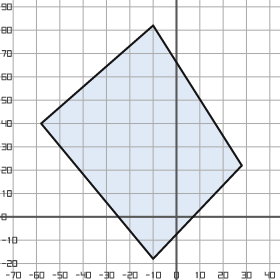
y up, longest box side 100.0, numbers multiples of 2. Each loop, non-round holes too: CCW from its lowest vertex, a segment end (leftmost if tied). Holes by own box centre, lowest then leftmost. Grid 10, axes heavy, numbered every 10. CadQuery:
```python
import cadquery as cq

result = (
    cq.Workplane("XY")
    .moveTo(-10.0, -18.0)
    .lineTo(28.0, 22.0)
    .lineTo(-10.0, 82.0)
    .lineTo(-58.0, 40.0)
    .close()
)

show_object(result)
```